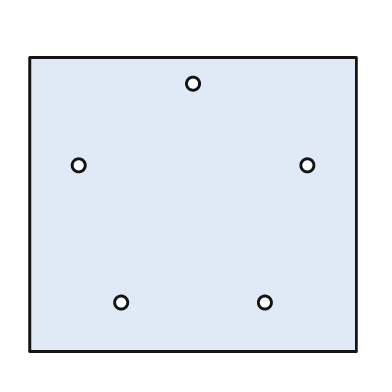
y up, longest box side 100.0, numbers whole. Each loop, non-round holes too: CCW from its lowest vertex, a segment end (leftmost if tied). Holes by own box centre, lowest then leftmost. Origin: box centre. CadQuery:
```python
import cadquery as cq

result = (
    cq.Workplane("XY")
    .moveTo(-50.0, -45.0)
    .lineTo(50.0, -45.0)
    .lineTo(50.0, 45.0)
    .lineTo(-50.0, 45.0)
    .close()
    .moveTo(-22.0, -30.0)
    .circle(2.0)
    .moveTo(22.0, -30.0)
    .circle(2.0)
    .moveTo(-35.0, 12.0)
    .circle(2.0)
    .moveTo(35.0, 12.0)
    .circle(2.0)
    .moveTo(0.0, 37.0)
    .circle(2.0)
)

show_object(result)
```